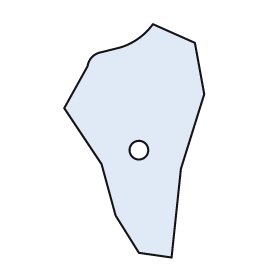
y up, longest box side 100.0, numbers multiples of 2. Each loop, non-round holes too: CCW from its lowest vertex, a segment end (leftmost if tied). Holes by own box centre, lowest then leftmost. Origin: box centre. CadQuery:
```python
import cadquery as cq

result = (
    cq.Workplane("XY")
    .moveTo(16.0, -50.0)
    .lineTo(20.0, -12.0)
    .lineTo(30.0, 20.0)
    .lineTo(26.0, 42.0)
    .lineTo(8.0, 50.0)
    .threePointArc((2.0, 44.0), (-6.0, 40.0))
    .lineTo(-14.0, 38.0)
    .threePointArc((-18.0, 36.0), (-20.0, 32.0))
    .lineTo(-30.0, 14.0)
    .lineTo(-14.0, -10.0)
    .lineTo(-8.0, -32.0)
    .lineTo(2.0, -48.0)
    .close()
    .moveTo(2.0, -4.0)
    .circle(4.0)
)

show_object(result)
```